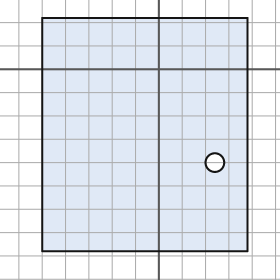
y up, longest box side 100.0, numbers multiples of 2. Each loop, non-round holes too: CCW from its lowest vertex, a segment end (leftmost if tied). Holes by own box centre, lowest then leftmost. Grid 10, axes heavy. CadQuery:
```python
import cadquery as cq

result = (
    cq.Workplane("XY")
    .moveTo(-50.0, -78.0)
    .lineTo(38.0, -78.0)
    .lineTo(38.0, 22.0)
    .lineTo(-50.0, 22.0)
    .close()
    .moveTo(24.0, -40.0)
    .circle(4.0)
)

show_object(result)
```